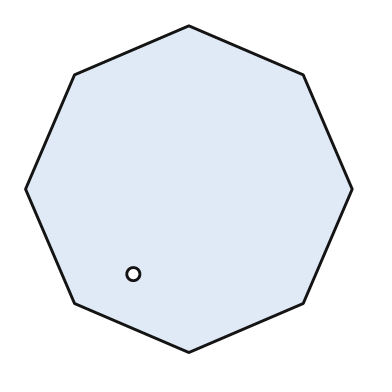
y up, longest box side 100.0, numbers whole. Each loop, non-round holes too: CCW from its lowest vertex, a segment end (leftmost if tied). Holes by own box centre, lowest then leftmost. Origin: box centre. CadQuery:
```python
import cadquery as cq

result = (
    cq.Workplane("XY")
    .moveTo(0.0, -50.0)
    .lineTo(35.0, -35.0)
    .lineTo(50.0, 0.0)
    .lineTo(35.0, 35.0)
    .lineTo(0.0, 50.0)
    .lineTo(-35.0, 35.0)
    .lineTo(-50.0, 0.0)
    .lineTo(-35.0, -35.0)
    .close()
    .moveTo(-17.0, -26.0)
    .circle(2.0)
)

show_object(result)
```